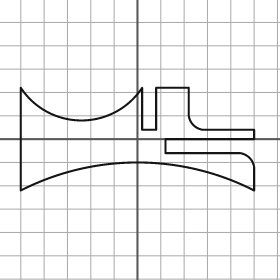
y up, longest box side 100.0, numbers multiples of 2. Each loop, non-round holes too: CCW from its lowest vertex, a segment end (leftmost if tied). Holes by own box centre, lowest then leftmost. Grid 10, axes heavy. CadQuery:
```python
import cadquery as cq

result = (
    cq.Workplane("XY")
    .moveTo(-50.0, -22.0)
    .threePointArc((0.0, -10.0), (50.0, -22.0))
    .lineTo(50.0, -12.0)
    .threePointArc((48.0, -8.0), (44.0, -6.0))
    .lineTo(12.0, -6.0)
    .lineTo(12.0, 0.0)
    .lineTo(50.0, 0.0)
    .lineTo(50.0, 4.0)
    .lineTo(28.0, 4.0)
    .threePointArc((24.0, 6.0), (22.0, 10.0))
    .lineTo(22.0, 22.0)
    .lineTo(8.0, 22.0)
    .lineTo(8.0, 4.0)
    .lineTo(2.0, 4.0)
    .lineTo(2.0, 22.0)
    .threePointArc((-24.0, 8.0), (-50.0, 22.0))
    .close()
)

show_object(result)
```